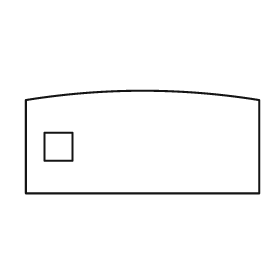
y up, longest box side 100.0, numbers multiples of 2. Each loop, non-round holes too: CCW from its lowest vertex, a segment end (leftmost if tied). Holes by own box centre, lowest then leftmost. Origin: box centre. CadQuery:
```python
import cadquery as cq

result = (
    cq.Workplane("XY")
    .moveTo(-50.0, -22.0)
    .lineTo(50.0, -22.0)
    .lineTo(50.0, 18.0)
    .threePointArc((0.0, 22.0), (-50.0, 18.0))
    .close()
    .moveTo(-42.0, -8.0)
    .lineTo(-30.0, -8.0)
    .lineTo(-30.0, 4.0)
    .lineTo(-42.0, 4.0)
    .close()
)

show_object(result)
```